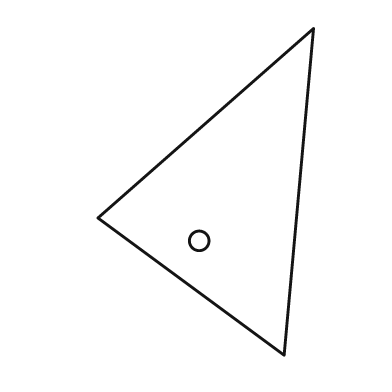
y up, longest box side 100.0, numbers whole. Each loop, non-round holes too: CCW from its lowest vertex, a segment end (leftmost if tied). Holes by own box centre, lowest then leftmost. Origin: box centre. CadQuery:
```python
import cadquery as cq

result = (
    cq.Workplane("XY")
    .moveTo(24.0, -50.0)
    .lineTo(33.0, 50.0)
    .lineTo(-33.0, -8.0)
    .close()
    .moveTo(-2.0, -15.0)
    .circle(3.0)
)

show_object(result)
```